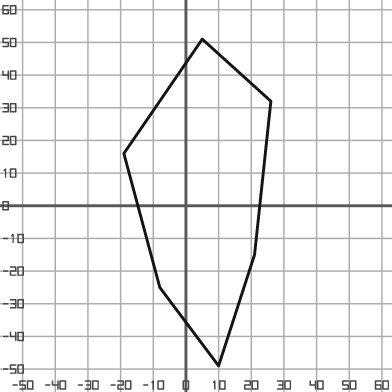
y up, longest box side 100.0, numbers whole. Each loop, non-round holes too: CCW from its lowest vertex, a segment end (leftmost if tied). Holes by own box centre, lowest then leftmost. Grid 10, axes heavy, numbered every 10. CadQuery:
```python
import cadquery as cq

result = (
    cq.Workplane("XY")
    .moveTo(10.0, -49.0)
    .lineTo(21.0, -15.0)
    .lineTo(26.0, 32.0)
    .lineTo(5.0, 51.0)
    .lineTo(-19.0, 16.0)
    .lineTo(-8.0, -25.0)
    .close()
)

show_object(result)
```